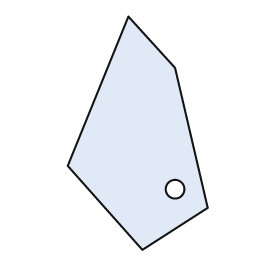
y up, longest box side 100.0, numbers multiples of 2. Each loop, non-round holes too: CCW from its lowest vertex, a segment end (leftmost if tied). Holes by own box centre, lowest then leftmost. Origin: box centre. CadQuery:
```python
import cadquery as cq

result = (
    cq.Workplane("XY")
    .moveTo(2.0, -50.0)
    .lineTo(30.0, -32.0)
    .lineTo(16.0, 28.0)
    .lineTo(-4.0, 50.0)
    .lineTo(-30.0, -14.0)
    .close()
    .moveTo(16.0, -24.0)
    .circle(4.0)
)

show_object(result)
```